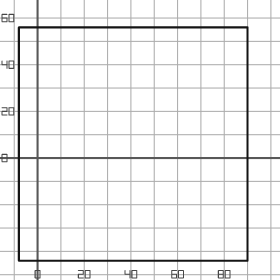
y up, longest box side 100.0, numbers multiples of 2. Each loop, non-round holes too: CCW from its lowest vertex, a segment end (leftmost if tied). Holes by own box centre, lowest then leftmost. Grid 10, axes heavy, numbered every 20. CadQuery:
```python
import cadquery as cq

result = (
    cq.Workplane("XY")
    .moveTo(-8.0, -44.0)
    .lineTo(90.0, -44.0)
    .lineTo(90.0, 56.0)
    .lineTo(-8.0, 56.0)
    .close()
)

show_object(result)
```